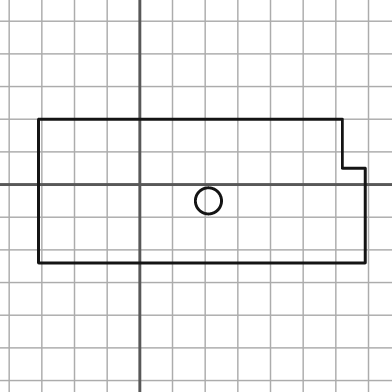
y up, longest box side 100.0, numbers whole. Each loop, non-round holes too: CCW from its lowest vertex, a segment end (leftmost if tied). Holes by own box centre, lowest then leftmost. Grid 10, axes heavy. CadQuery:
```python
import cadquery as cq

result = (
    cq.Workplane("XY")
    .moveTo(-31.0, -24.0)
    .lineTo(69.0, -24.0)
    .lineTo(69.0, 5.0)
    .lineTo(62.0, 5.0)
    .lineTo(62.0, 20.0)
    .lineTo(-31.0, 20.0)
    .close()
    .moveTo(21.0, -5.0)
    .circle(4.0)
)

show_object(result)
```